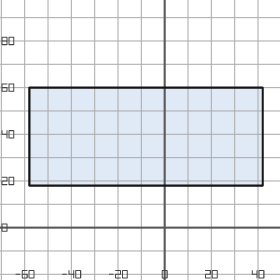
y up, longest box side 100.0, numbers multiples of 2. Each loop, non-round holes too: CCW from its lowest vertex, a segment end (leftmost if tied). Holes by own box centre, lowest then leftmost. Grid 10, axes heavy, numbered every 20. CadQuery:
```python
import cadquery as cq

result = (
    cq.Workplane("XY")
    .moveTo(-58.0, 18.0)
    .lineTo(42.0, 18.0)
    .lineTo(42.0, 60.0)
    .lineTo(-58.0, 60.0)
    .close()
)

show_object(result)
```